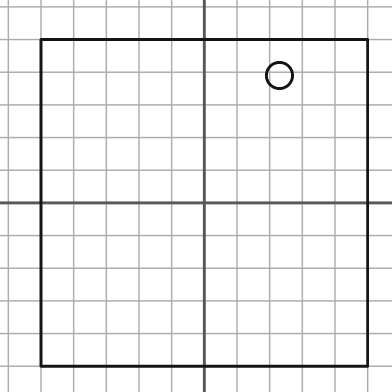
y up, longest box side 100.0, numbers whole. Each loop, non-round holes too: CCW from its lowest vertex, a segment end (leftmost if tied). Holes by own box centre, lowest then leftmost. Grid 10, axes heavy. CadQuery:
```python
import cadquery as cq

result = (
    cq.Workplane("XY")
    .moveTo(-50.0, -50.0)
    .lineTo(50.0, -50.0)
    .lineTo(50.0, 50.0)
    .lineTo(-50.0, 50.0)
    .close()
    .moveTo(23.0, 39.0)
    .circle(4.0)
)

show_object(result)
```